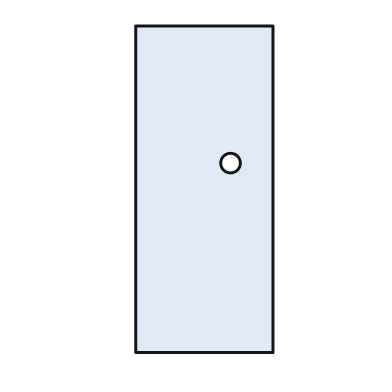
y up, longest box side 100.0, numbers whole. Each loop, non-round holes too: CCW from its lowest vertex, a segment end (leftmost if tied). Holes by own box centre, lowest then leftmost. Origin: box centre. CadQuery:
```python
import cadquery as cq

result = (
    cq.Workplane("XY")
    .moveTo(-21.0, -50.0)
    .lineTo(21.0, -50.0)
    .lineTo(21.0, 50.0)
    .lineTo(-21.0, 50.0)
    .close()
    .moveTo(8.0, 8.0)
    .circle(3.0)
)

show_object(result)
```